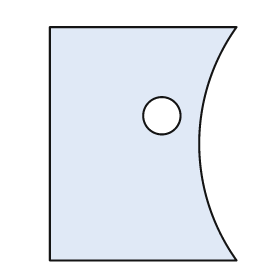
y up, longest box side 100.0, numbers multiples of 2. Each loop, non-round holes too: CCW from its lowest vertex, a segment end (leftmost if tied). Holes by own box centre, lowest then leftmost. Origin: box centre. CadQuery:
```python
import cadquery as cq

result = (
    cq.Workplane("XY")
    .moveTo(-40.0, -50.0)
    .lineTo(40.0, -50.0)
    .threePointArc((24.0, 0.0), (40.0, 50.0))
    .lineTo(-40.0, 50.0)
    .close()
    .moveTo(8.0, 12.0)
    .circle(8.0)
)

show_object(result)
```